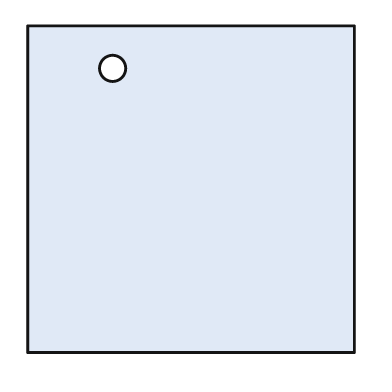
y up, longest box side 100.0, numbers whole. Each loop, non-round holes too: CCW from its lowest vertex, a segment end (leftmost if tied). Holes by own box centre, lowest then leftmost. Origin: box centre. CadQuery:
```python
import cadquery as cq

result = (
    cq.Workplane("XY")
    .moveTo(-50.0, -50.0)
    .lineTo(50.0, -50.0)
    .lineTo(50.0, 50.0)
    .lineTo(-50.0, 50.0)
    .close()
    .moveTo(-24.0, 37.0)
    .circle(4.0)
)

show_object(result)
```